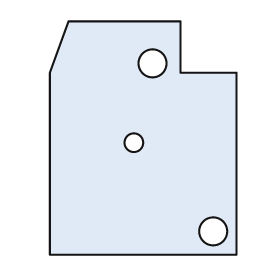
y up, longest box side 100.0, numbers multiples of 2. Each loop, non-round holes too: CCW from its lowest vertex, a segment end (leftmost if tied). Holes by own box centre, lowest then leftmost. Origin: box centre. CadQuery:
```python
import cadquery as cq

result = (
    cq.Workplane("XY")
    .moveTo(-40.0, -50.0)
    .lineTo(40.0, -50.0)
    .lineTo(40.0, 28.0)
    .lineTo(16.0, 28.0)
    .lineTo(16.0, 50.0)
    .lineTo(-32.0, 50.0)
    .lineTo(-40.0, 28.0)
    .close()
    .moveTo(30.0, -40.0)
    .circle(6.0)
    .moveTo(-4.0, -2.0)
    .circle(4.0)
    .moveTo(4.0, 32.0)
    .circle(6.0)
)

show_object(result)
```